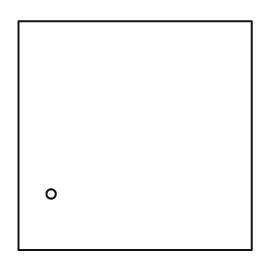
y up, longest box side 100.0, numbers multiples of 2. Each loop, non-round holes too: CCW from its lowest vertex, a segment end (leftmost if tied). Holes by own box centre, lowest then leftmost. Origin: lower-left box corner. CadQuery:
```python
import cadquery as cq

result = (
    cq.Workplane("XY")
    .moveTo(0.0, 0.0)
    .lineTo(100.0, 0.0)
    .lineTo(100.0, 98.0)
    .lineTo(0.0, 98.0)
    .close()
    .moveTo(14.0, 24.0)
    .circle(2.0)
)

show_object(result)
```